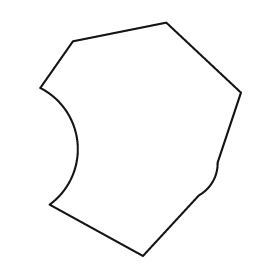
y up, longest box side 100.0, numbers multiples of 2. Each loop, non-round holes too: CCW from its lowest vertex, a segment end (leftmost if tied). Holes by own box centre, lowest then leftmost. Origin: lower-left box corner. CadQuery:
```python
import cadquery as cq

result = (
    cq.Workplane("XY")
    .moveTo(44.0, 0.0)
    .lineTo(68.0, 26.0)
    .threePointArc((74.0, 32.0), (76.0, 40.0))
    .lineTo(86.0, 70.0)
    .lineTo(54.0, 100.0)
    .lineTo(14.0, 92.0)
    .lineTo(0.0, 72.0)
    .threePointArc((16.0, 48.0), (4.0, 22.0))
    .close()
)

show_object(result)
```